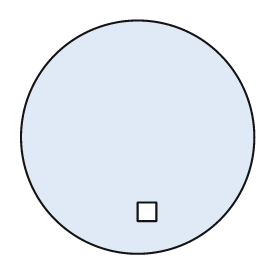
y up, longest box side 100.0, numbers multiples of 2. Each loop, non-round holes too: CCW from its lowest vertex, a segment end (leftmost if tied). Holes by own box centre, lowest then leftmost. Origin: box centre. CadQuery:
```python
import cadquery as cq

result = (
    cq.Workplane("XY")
    .moveTo(0.0, 0.0)
    .circle(50.0)
    .moveTo(0.0, -36.0)
    .lineTo(8.0, -36.0)
    .lineTo(8.0, -28.0)
    .lineTo(0.0, -28.0)
    .close()
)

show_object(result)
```